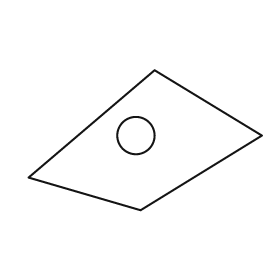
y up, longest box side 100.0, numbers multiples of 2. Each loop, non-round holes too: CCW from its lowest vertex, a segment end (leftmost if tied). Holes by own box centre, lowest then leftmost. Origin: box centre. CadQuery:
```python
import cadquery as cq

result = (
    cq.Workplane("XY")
    .moveTo(-2.0, -30.0)
    .lineTo(50.0, 2.0)
    .lineTo(4.0, 30.0)
    .lineTo(-50.0, -16.0)
    .close()
    .moveTo(-4.0, 2.0)
    .circle(8.0)
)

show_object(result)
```